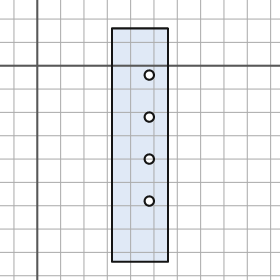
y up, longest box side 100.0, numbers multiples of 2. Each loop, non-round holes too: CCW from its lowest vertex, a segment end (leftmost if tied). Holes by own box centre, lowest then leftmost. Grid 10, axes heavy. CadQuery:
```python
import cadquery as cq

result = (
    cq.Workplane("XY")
    .moveTo(32.0, -84.0)
    .lineTo(56.0, -84.0)
    .lineTo(56.0, 16.0)
    .lineTo(32.0, 16.0)
    .close()
    .moveTo(48.0, -58.0)
    .circle(2.0)
    .moveTo(48.0, -40.0)
    .circle(2.0)
    .moveTo(48.0, -22.0)
    .circle(2.0)
    .moveTo(48.0, -4.0)
    .circle(2.0)
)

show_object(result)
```